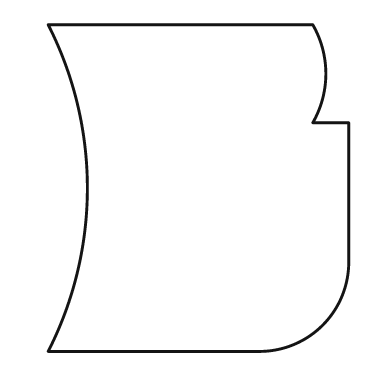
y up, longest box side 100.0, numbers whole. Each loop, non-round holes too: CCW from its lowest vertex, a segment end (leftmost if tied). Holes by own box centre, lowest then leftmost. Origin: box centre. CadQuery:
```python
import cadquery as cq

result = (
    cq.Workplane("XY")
    .moveTo(-46.0, -50.0)
    .lineTo(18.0, -50.0)
    .threePointArc((38.0, -42.0), (46.0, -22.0))
    .lineTo(46.0, 20.0)
    .lineTo(35.0, 20.0)
    .threePointArc((39.0, 35.0), (35.0, 50.0))
    .lineTo(-46.0, 50.0)
    .threePointArc((-34.0, 0.0), (-46.0, -50.0))
    .close()
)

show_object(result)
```